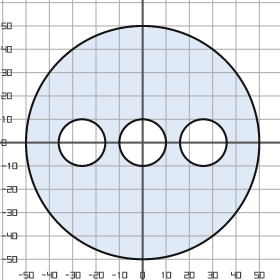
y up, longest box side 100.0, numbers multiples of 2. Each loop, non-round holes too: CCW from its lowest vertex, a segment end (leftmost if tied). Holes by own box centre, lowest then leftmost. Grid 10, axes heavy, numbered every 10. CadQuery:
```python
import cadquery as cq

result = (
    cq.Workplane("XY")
    .moveTo(0.0, 0.0)
    .circle(50.0)
    .moveTo(-26.0, 0.0)
    .circle(10.0)
    .moveTo(0.0, 0.0)
    .circle(10.0)
    .moveTo(26.0, 0.0)
    .circle(10.0)
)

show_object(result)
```